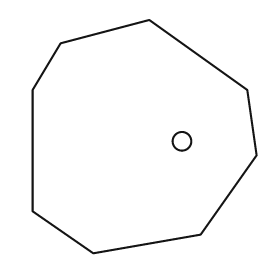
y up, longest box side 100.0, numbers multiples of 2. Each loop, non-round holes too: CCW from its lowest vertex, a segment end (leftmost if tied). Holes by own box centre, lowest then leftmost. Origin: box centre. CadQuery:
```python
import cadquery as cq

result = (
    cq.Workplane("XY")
    .moveTo(-22.0, -50.0)
    .lineTo(24.0, -42.0)
    .lineTo(48.0, -8.0)
    .lineTo(44.0, 20.0)
    .lineTo(2.0, 50.0)
    .lineTo(-36.0, 40.0)
    .lineTo(-48.0, 20.0)
    .lineTo(-48.0, -32.0)
    .close()
    .moveTo(16.0, -2.0)
    .circle(4.0)
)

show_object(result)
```